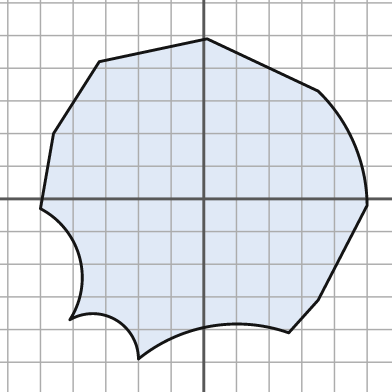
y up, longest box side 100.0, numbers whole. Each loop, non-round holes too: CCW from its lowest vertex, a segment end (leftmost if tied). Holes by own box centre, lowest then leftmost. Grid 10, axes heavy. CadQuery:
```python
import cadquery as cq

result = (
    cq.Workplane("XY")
    .moveTo(-20.0, -49.0)
    .threePointArc((2.0, -39.0), (26.0, -41.0))
    .lineTo(35.0, -31.0)
    .lineTo(50.0, -2.0)
    .threePointArc((46.0, 17.0), (35.0, 33.0))
    .lineTo(1.0, 49.0)
    .lineTo(-32.0, 42.0)
    .lineTo(-46.0, 20.0)
    .lineTo(-50.0, -3.0)
    .threePointArc((-38.0, -18.0), (-41.0, -37.0))
    .threePointArc((-27.0, -37.0), (-20.0, -49.0))
    .close()
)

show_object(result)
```